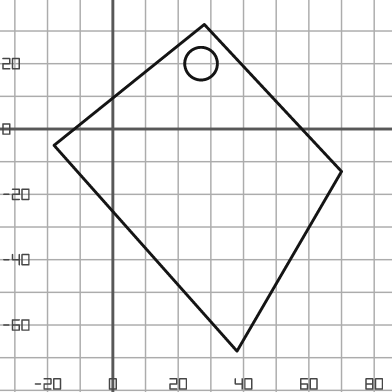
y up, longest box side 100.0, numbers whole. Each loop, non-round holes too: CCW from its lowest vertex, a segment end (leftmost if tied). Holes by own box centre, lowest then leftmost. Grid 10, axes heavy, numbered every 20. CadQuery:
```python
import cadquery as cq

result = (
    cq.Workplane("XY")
    .moveTo(38.0, -68.0)
    .lineTo(70.0, -13.0)
    .lineTo(28.0, 32.0)
    .lineTo(-18.0, -5.0)
    .close()
    .moveTo(27.0, 20.0)
    .circle(5.0)
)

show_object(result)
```